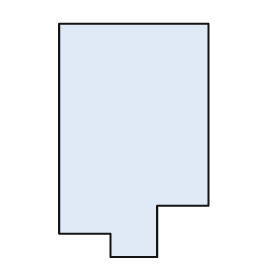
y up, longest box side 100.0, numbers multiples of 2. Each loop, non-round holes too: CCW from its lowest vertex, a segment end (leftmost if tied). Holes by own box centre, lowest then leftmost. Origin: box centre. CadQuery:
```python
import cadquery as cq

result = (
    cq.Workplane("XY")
    .moveTo(-10.0, -50.0)
    .lineTo(10.0, -50.0)
    .lineTo(10.0, -28.0)
    .lineTo(32.0, -28.0)
    .lineTo(32.0, 50.0)
    .lineTo(-32.0, 50.0)
    .lineTo(-32.0, -40.0)
    .lineTo(-10.0, -40.0)
    .close()
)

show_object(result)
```